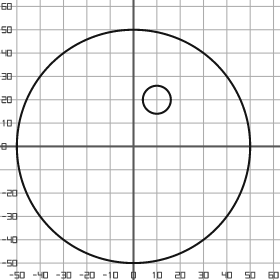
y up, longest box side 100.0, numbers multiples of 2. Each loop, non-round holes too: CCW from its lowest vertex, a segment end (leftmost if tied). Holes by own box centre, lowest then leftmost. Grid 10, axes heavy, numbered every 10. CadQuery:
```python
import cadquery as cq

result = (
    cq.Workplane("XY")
    .moveTo(0.0, 0.0)
    .circle(50.0)
    .moveTo(10.0, 20.0)
    .circle(6.0)
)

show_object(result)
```